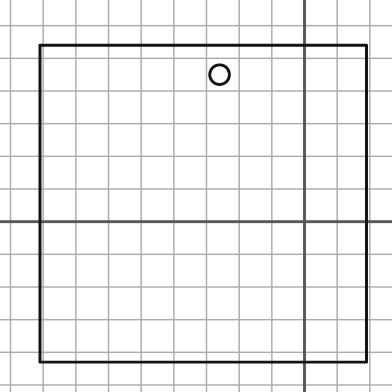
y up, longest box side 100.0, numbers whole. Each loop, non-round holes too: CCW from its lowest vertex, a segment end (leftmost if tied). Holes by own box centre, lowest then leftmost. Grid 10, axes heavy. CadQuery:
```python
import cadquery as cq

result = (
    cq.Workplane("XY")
    .moveTo(-81.0, -43.0)
    .lineTo(19.0, -43.0)
    .lineTo(19.0, 54.0)
    .lineTo(-81.0, 54.0)
    .close()
    .moveTo(-26.0, 45.0)
    .circle(3.0)
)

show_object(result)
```